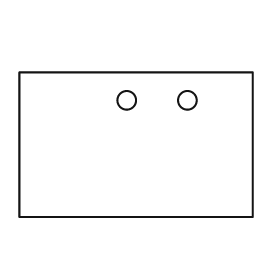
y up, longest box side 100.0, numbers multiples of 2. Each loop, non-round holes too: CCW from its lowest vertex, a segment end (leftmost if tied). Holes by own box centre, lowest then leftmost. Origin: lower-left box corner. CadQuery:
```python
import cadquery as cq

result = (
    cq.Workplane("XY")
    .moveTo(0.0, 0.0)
    .lineTo(100.0, 0.0)
    .lineTo(100.0, 62.0)
    .lineTo(0.0, 62.0)
    .close()
    .moveTo(46.0, 50.0)
    .circle(4.0)
    .moveTo(72.0, 50.0)
    .circle(4.0)
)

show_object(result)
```